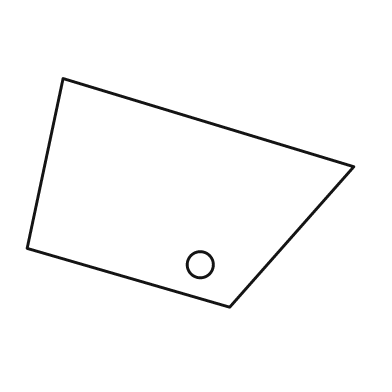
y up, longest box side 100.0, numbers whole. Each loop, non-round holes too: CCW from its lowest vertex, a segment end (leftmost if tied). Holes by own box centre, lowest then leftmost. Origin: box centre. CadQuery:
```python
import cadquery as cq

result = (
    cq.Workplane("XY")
    .moveTo(12.0, -35.0)
    .lineTo(50.0, 8.0)
    .lineTo(-39.0, 35.0)
    .lineTo(-50.0, -17.0)
    .close()
    .moveTo(3.0, -22.0)
    .circle(4.0)
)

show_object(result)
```